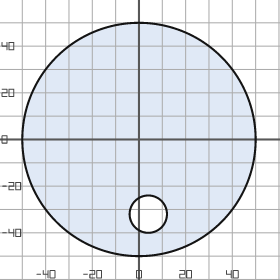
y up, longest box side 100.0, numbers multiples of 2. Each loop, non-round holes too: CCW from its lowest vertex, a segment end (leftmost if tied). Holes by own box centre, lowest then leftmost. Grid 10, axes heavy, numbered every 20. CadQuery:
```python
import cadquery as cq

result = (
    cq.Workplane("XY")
    .moveTo(0.0, 0.0)
    .circle(50.0)
    .moveTo(4.0, -32.0)
    .circle(8.0)
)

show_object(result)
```